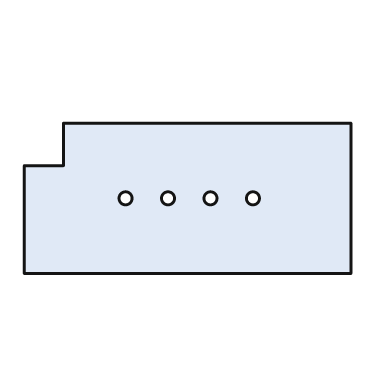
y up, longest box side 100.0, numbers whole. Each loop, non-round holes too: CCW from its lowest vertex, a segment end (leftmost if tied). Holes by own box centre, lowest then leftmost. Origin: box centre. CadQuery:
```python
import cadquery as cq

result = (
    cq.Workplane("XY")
    .moveTo(-50.0, -23.0)
    .lineTo(50.0, -23.0)
    .lineTo(50.0, 23.0)
    .lineTo(-38.0, 23.0)
    .lineTo(-38.0, 10.0)
    .lineTo(-50.0, 10.0)
    .close()
    .moveTo(-19.0, 0.0)
    .circle(2.0)
    .moveTo(-6.0, 0.0)
    .circle(2.0)
    .moveTo(7.0, 0.0)
    .circle(2.0)
    .moveTo(20.0, 0.0)
    .circle(2.0)
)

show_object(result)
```